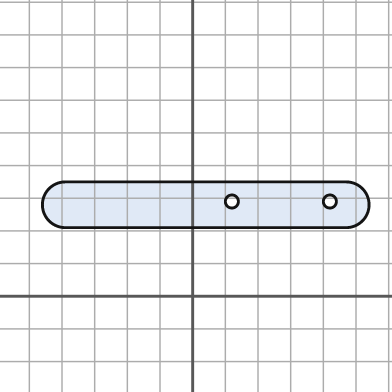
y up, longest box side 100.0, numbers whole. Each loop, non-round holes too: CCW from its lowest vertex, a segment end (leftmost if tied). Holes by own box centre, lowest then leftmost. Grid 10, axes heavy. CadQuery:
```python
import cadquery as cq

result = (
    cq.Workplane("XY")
    .moveTo(-39.0, 21.0)
    .lineTo(47.0, 21.0)
    .threePointArc((54.0, 28.0), (47.0, 35.0))
    .lineTo(-39.0, 35.0)
    .threePointArc((-46.0, 28.0), (-39.0, 21.0))
    .close()
    .moveTo(12.0, 29.0)
    .circle(2.0)
    .moveTo(42.0, 29.0)
    .circle(2.0)
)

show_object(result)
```